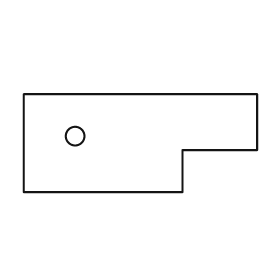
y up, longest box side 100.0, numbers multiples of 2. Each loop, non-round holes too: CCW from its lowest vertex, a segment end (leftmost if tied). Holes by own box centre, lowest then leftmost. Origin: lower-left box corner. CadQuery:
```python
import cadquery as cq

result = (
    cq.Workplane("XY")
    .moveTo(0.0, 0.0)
    .lineTo(68.0, 0.0)
    .lineTo(68.0, 18.0)
    .lineTo(100.0, 18.0)
    .lineTo(100.0, 42.0)
    .lineTo(0.0, 42.0)
    .close()
    .moveTo(22.0, 24.0)
    .circle(4.0)
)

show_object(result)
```